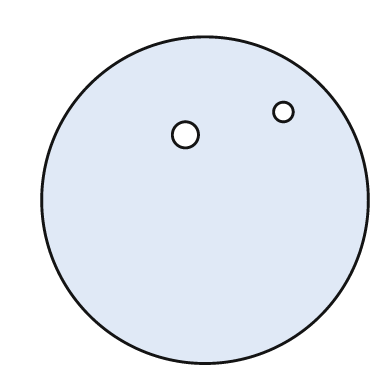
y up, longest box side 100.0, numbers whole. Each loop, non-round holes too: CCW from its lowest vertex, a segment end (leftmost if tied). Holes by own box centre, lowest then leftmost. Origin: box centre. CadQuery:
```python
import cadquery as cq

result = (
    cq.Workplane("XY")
    .moveTo(0.0, 0.0)
    .circle(50.0)
    .moveTo(-6.0, 20.0)
    .circle(4.0)
    .moveTo(24.0, 27.0)
    .circle(3.0)
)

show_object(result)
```